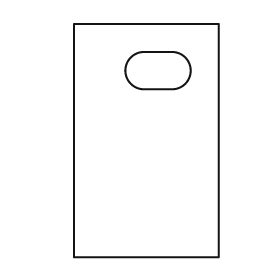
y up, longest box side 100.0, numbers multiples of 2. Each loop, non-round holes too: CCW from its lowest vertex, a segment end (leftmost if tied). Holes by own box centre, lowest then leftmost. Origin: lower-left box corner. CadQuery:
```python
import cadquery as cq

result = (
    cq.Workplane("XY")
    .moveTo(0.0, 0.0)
    .lineTo(62.0, 0.0)
    .lineTo(62.0, 100.0)
    .lineTo(0.0, 100.0)
    .close()
    .moveTo(30.0, 72.0)
    .lineTo(42.0, 72.0)
    .threePointArc((50.0, 80.0), (42.0, 88.0))
    .lineTo(30.0, 88.0)
    .threePointArc((22.0, 80.0), (30.0, 72.0))
    .close()
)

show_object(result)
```